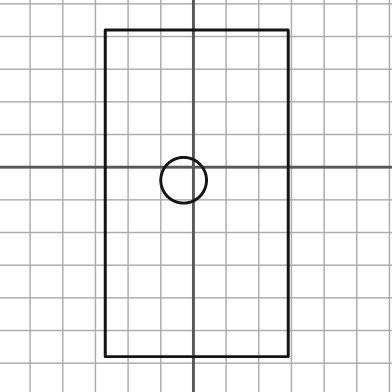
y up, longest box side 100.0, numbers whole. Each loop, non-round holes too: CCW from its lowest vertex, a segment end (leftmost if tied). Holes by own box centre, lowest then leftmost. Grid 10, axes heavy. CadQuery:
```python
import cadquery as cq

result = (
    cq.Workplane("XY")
    .moveTo(-27.0, -58.0)
    .lineTo(29.0, -58.0)
    .lineTo(29.0, 42.0)
    .lineTo(-27.0, 42.0)
    .close()
    .moveTo(-3.0, -4.0)
    .circle(7.0)
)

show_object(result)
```